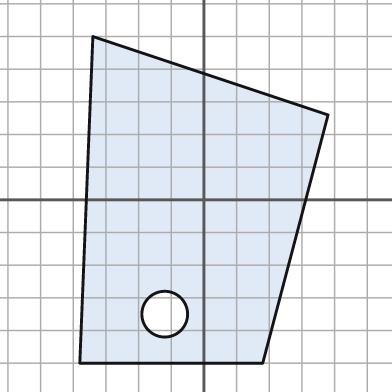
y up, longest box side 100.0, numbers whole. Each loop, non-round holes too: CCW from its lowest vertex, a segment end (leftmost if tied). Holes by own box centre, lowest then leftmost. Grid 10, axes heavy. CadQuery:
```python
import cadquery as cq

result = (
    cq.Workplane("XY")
    .moveTo(-38.0, -50.0)
    .lineTo(18.0, -50.0)
    .lineTo(38.0, 26.0)
    .lineTo(-34.0, 50.0)
    .close()
    .moveTo(-12.0, -35.0)
    .circle(7.0)
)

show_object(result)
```